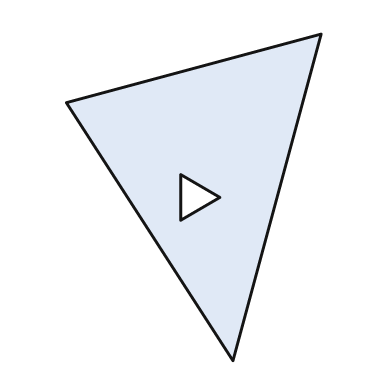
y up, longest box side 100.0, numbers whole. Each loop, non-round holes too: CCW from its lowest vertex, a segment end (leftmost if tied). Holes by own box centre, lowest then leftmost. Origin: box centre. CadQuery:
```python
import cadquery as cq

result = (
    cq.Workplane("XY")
    .moveTo(12.0, -50.0)
    .lineTo(39.0, 50.0)
    .lineTo(-39.0, 29.0)
    .close()
    .moveTo(-4.0, -7.0)
    .lineTo(8.0, 0.0)
    .lineTo(-4.0, 7.0)
    .close()
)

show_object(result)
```